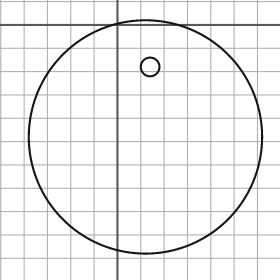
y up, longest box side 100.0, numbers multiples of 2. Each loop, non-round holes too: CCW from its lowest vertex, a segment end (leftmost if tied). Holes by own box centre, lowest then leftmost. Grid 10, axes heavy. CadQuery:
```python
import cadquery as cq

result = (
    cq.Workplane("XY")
    .moveTo(12.0, -48.0)
    .circle(50.0)
    .moveTo(14.0, -18.0)
    .circle(4.0)
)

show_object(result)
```